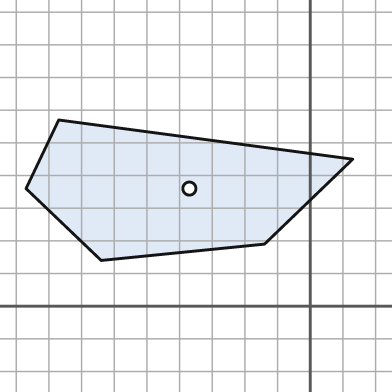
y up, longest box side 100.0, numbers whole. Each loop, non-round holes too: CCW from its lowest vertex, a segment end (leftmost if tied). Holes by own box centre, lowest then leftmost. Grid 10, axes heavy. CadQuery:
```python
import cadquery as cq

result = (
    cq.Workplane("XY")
    .moveTo(-64.0, 14.0)
    .lineTo(-14.0, 19.0)
    .lineTo(13.0, 45.0)
    .lineTo(-77.0, 57.0)
    .lineTo(-87.0, 36.0)
    .close()
    .moveTo(-37.0, 36.0)
    .circle(2.0)
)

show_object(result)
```